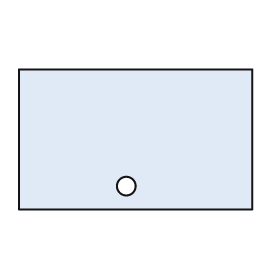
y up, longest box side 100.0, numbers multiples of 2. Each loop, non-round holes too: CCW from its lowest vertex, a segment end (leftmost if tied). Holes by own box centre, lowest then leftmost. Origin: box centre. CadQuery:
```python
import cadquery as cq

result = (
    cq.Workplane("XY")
    .moveTo(-50.0, -30.0)
    .lineTo(50.0, -30.0)
    .lineTo(50.0, 30.0)
    .lineTo(-50.0, 30.0)
    .close()
    .moveTo(-4.0, -20.0)
    .circle(4.0)
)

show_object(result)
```